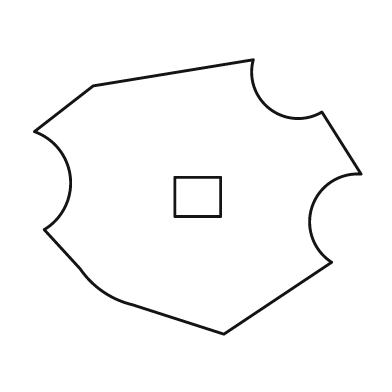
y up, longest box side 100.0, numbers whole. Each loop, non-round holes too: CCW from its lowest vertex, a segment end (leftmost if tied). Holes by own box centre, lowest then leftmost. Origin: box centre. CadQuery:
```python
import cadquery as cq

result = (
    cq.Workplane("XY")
    .moveTo(8.0, -42.0)
    .lineTo(41.0, -20.0)
    .threePointArc((35.0, -3.0), (50.0, 7.0))
    .lineTo(38.0, 26.0)
    .threePointArc((22.0, 27.0), (17.0, 42.0))
    .lineTo(-32.0, 34.0)
    .lineTo(-50.0, 20.0)
    .threePointArc((-39.0, 6.0), (-47.0, -10.0))
    .lineTo(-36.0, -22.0)
    .threePointArc((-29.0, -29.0), (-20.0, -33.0))
    .close()
    .moveTo(-7.0, -6.0)
    .lineTo(7.0, -6.0)
    .lineTo(7.0, 6.0)
    .lineTo(-7.0, 6.0)
    .close()
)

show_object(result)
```